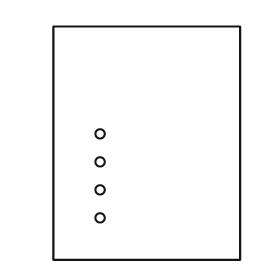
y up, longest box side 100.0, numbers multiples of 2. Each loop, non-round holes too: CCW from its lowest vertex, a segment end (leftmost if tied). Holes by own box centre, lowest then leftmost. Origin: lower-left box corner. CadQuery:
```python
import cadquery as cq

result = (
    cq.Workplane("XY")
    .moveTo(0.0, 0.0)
    .lineTo(80.0, 0.0)
    .lineTo(80.0, 100.0)
    .lineTo(0.0, 100.0)
    .close()
    .moveTo(20.0, 18.0)
    .circle(2.0)
    .moveTo(20.0, 30.0)
    .circle(2.0)
    .moveTo(20.0, 42.0)
    .circle(2.0)
    .moveTo(20.0, 54.0)
    .circle(2.0)
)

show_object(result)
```